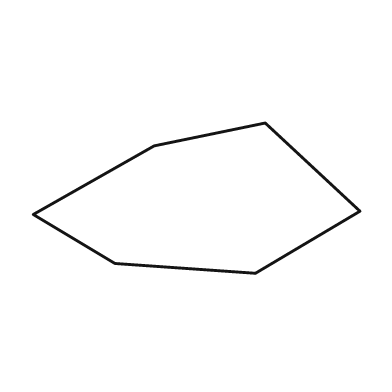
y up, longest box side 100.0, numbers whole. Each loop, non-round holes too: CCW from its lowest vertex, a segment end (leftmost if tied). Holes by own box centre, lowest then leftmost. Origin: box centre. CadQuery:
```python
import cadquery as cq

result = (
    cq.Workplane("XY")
    .moveTo(18.0, -23.0)
    .lineTo(50.0, -4.0)
    .lineTo(21.0, 23.0)
    .lineTo(-13.0, 16.0)
    .lineTo(-50.0, -5.0)
    .lineTo(-25.0, -20.0)
    .close()
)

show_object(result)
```